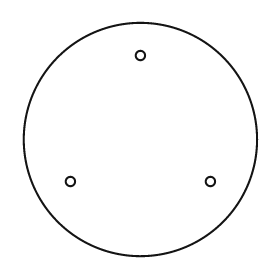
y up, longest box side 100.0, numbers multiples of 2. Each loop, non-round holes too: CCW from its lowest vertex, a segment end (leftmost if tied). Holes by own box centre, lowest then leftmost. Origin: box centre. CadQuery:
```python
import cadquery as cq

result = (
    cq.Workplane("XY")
    .moveTo(0.0, 0.0)
    .circle(50.0)
    .moveTo(-30.0, -18.0)
    .circle(2.0)
    .moveTo(30.0, -18.0)
    .circle(2.0)
    .moveTo(0.0, 36.0)
    .circle(2.0)
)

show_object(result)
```